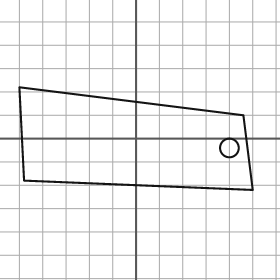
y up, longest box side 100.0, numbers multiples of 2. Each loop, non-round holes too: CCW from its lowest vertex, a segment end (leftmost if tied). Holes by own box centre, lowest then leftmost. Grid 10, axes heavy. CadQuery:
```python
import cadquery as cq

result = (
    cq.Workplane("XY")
    .moveTo(50.0, -22.0)
    .lineTo(46.0, 10.0)
    .lineTo(-50.0, 22.0)
    .lineTo(-48.0, -18.0)
    .close()
    .moveTo(40.0, -4.0)
    .circle(4.0)
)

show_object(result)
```